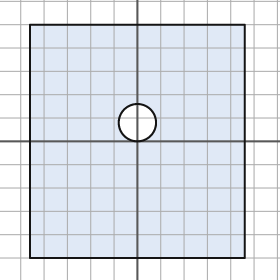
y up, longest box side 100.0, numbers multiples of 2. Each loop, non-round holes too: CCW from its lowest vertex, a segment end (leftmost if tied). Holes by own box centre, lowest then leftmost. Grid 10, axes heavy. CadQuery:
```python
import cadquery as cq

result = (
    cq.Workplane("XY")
    .moveTo(-46.0, -50.0)
    .lineTo(46.0, -50.0)
    .lineTo(46.0, 50.0)
    .lineTo(-46.0, 50.0)
    .close()
    .moveTo(0.0, 8.0)
    .circle(8.0)
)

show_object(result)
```